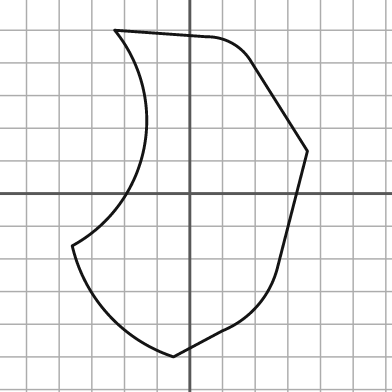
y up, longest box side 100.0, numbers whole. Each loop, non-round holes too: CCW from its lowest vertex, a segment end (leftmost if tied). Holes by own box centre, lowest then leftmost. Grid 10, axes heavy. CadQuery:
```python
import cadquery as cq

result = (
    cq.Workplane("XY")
    .moveTo(-5.0, -50.0)
    .lineTo(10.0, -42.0)
    .threePointArc((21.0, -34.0), (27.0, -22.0))
    .lineTo(36.0, 13.0)
    .lineTo(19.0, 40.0)
    .threePointArc((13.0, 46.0), (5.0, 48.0))
    .lineTo(-23.0, 50.0)
    .threePointArc((-14.0, 14.0), (-36.0, -16.0))
    .threePointArc((-25.0, -37.0), (-5.0, -50.0))
    .close()
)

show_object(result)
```